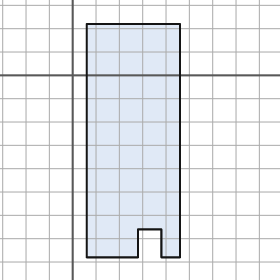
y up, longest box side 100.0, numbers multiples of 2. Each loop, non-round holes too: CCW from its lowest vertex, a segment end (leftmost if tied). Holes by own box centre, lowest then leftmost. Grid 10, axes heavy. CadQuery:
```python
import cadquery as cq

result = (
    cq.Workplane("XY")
    .moveTo(6.0, -78.0)
    .lineTo(28.0, -78.0)
    .lineTo(28.0, -66.0)
    .lineTo(38.0, -66.0)
    .lineTo(38.0, -78.0)
    .lineTo(46.0, -78.0)
    .lineTo(46.0, 22.0)
    .lineTo(6.0, 22.0)
    .close()
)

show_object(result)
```